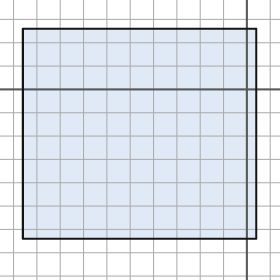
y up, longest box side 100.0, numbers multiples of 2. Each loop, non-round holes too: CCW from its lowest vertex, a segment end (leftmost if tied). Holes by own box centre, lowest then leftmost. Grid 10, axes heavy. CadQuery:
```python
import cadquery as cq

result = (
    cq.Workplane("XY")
    .moveTo(-96.0, -64.0)
    .lineTo(4.0, -64.0)
    .lineTo(4.0, 26.0)
    .lineTo(-96.0, 26.0)
    .close()
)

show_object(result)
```